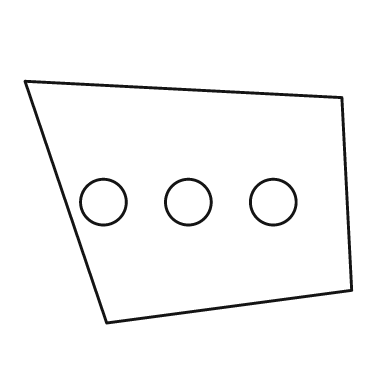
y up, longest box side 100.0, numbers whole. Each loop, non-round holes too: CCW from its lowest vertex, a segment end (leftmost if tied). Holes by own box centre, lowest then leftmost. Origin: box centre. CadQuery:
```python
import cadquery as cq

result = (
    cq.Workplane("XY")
    .moveTo(-25.0, -37.0)
    .lineTo(50.0, -27.0)
    .lineTo(47.0, 32.0)
    .lineTo(-50.0, 37.0)
    .close()
    .moveTo(-26.0, 0.0)
    .circle(7.0)
    .moveTo(0.0, 0.0)
    .circle(7.0)
    .moveTo(26.0, 0.0)
    .circle(7.0)
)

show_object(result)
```